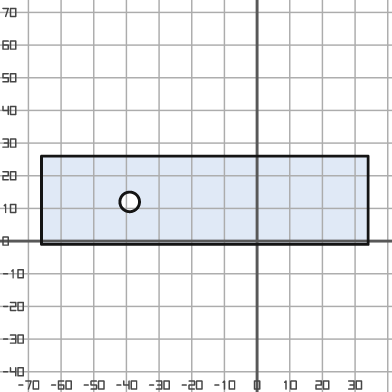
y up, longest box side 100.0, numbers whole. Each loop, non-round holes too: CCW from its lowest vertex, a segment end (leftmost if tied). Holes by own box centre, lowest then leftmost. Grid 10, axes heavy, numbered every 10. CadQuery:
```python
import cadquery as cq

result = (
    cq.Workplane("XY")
    .moveTo(-66.0, -1.0)
    .lineTo(34.0, -1.0)
    .lineTo(34.0, 26.0)
    .lineTo(-66.0, 26.0)
    .close()
    .moveTo(-39.0, 12.0)
    .circle(3.0)
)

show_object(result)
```